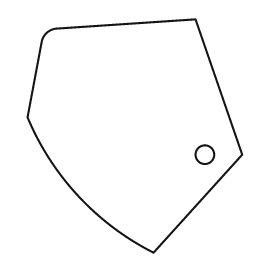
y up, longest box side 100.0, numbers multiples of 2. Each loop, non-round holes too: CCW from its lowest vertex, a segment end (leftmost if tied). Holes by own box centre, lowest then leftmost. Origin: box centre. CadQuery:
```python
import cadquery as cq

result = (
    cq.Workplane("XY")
    .moveTo(8.0, -50.0)
    .lineTo(46.0, -8.0)
    .lineTo(26.0, 50.0)
    .lineTo(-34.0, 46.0)
    .threePointArc((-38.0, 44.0), (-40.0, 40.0))
    .lineTo(-46.0, 8.0)
    .threePointArc((-24.0, -26.0), (8.0, -50.0))
    .close()
    .moveTo(30.0, -8.0)
    .circle(4.0)
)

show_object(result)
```